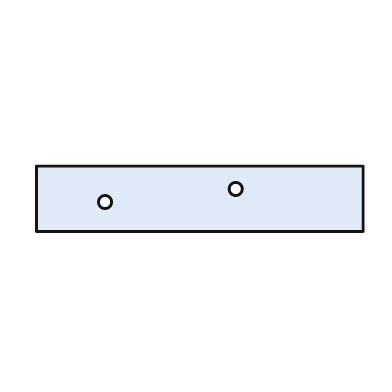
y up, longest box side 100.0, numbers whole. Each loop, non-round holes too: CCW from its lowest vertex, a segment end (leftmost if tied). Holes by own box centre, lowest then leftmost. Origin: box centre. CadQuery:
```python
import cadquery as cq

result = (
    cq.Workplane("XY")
    .moveTo(-50.0, -10.0)
    .lineTo(50.0, -10.0)
    .lineTo(50.0, 10.0)
    .lineTo(-50.0, 10.0)
    .close()
    .moveTo(-29.0, -1.0)
    .circle(2.0)
    .moveTo(11.0, 3.0)
    .circle(2.0)
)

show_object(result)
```